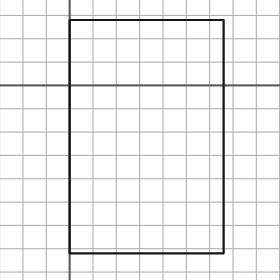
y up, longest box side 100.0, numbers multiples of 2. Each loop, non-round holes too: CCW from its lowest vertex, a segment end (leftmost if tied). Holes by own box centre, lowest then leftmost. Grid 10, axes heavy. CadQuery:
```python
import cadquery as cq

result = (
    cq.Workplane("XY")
    .moveTo(0.0, -72.0)
    .lineTo(66.0, -72.0)
    .lineTo(66.0, 28.0)
    .lineTo(0.0, 28.0)
    .close()
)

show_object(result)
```